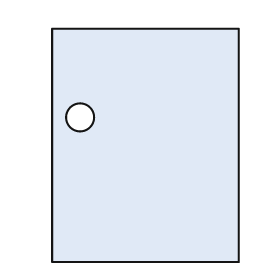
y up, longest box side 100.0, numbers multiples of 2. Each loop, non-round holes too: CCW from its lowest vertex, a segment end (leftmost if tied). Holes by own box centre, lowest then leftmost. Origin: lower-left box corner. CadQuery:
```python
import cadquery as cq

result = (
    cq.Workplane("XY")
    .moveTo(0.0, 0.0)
    .lineTo(80.0, 0.0)
    .lineTo(80.0, 100.0)
    .lineTo(0.0, 100.0)
    .close()
    .moveTo(12.0, 62.0)
    .circle(6.0)
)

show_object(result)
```